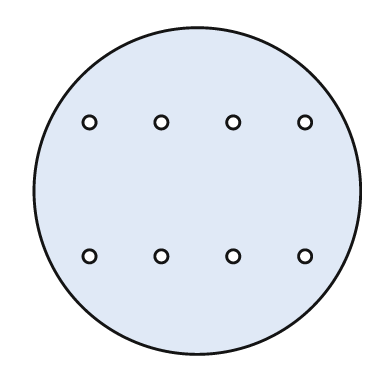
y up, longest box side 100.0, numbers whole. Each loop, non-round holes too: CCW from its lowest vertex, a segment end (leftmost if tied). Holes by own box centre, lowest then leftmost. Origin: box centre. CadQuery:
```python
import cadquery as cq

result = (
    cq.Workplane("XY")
    .moveTo(0.0, 0.0)
    .circle(50.0)
    .moveTo(-33.0, -20.0)
    .circle(2.0)
    .moveTo(-11.0, -20.0)
    .circle(2.0)
    .moveTo(11.0, -20.0)
    .circle(2.0)
    .moveTo(33.0, -20.0)
    .circle(2.0)
    .moveTo(-33.0, 21.0)
    .circle(2.0)
    .moveTo(-11.0, 21.0)
    .circle(2.0)
    .moveTo(11.0, 21.0)
    .circle(2.0)
    .moveTo(33.0, 21.0)
    .circle(2.0)
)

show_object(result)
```